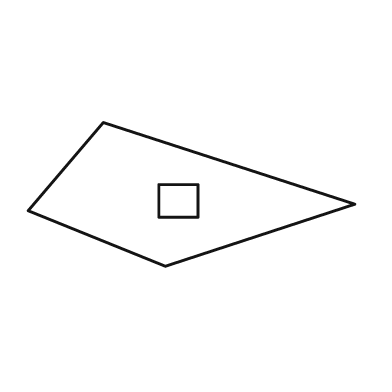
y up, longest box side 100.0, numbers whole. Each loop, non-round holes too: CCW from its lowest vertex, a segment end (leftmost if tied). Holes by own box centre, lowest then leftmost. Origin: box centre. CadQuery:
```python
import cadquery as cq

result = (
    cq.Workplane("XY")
    .moveTo(-8.0, -22.0)
    .lineTo(50.0, -3.0)
    .lineTo(-27.0, 22.0)
    .lineTo(-50.0, -5.0)
    .close()
    .moveTo(-10.0, -7.0)
    .lineTo(2.0, -7.0)
    .lineTo(2.0, 3.0)
    .lineTo(-10.0, 3.0)
    .close()
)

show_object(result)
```